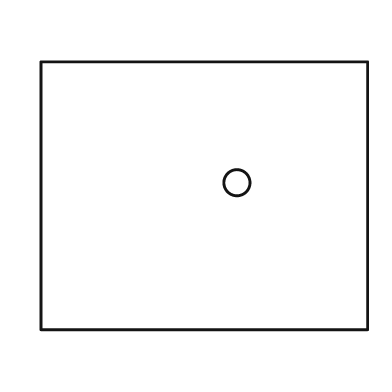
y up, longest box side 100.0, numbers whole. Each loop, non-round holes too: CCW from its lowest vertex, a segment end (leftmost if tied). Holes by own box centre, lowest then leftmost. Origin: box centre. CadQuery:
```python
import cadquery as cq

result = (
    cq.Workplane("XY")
    .moveTo(-50.0, -41.0)
    .lineTo(50.0, -41.0)
    .lineTo(50.0, 41.0)
    .lineTo(-50.0, 41.0)
    .close()
    .moveTo(10.0, 4.0)
    .circle(4.0)
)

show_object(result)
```